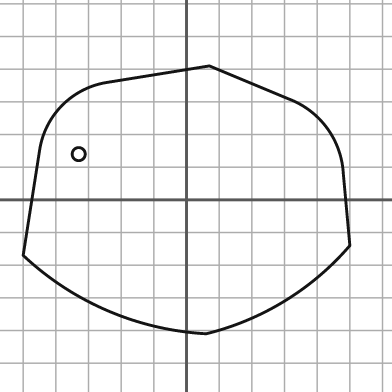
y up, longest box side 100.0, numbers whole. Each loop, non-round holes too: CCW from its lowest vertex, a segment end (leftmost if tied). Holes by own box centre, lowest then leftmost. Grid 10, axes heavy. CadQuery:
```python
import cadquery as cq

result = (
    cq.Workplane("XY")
    .moveTo(6.0, -41.0)
    .threePointArc((30.0, -31.0), (50.0, -14.0))
    .lineTo(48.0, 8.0)
    .threePointArc((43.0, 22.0), (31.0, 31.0))
    .lineTo(7.0, 41.0)
    .lineTo(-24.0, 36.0)
    .threePointArc((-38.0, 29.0), (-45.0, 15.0))
    .lineTo(-50.0, -17.0)
    .threePointArc((-24.0, -34.0), (6.0, -41.0))
    .close()
    .moveTo(-33.0, 14.0)
    .circle(2.0)
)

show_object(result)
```